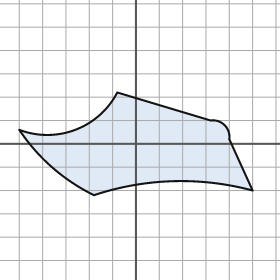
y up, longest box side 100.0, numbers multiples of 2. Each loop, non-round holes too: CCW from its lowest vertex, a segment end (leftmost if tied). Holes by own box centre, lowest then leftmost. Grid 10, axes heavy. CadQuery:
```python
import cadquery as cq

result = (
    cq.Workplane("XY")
    .moveTo(-18.0, -22.0)
    .threePointArc((16.0, -16.0), (50.0, -20.0))
    .lineTo(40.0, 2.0)
    .threePointArc((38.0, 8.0), (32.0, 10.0))
    .lineTo(-8.0, 22.0)
    .threePointArc((-26.0, 6.0), (-50.0, 6.0))
    .threePointArc((-36.0, -10.0), (-18.0, -22.0))
    .close()
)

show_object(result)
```